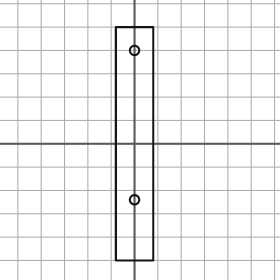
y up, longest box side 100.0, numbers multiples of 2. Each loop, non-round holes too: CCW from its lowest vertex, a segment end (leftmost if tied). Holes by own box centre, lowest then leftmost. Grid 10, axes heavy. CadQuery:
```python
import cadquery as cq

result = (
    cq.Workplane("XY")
    .moveTo(-8.0, -50.0)
    .lineTo(8.0, -50.0)
    .lineTo(8.0, 50.0)
    .lineTo(-8.0, 50.0)
    .close()
    .moveTo(0.0, -24.0)
    .circle(2.0)
    .moveTo(0.0, 40.0)
    .circle(2.0)
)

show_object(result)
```